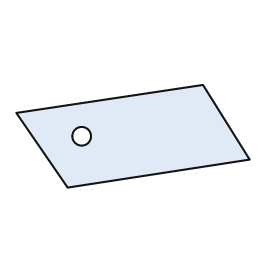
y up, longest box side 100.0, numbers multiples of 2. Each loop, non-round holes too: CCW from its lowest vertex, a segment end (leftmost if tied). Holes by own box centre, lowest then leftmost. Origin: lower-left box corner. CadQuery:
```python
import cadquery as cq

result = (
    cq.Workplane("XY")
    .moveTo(22.0, 0.0)
    .lineTo(100.0, 12.0)
    .lineTo(80.0, 44.0)
    .lineTo(0.0, 32.0)
    .close()
    .moveTo(28.0, 22.0)
    .circle(4.0)
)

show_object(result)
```